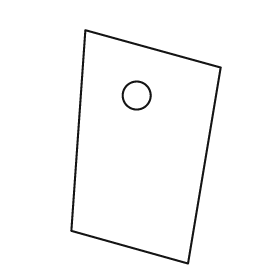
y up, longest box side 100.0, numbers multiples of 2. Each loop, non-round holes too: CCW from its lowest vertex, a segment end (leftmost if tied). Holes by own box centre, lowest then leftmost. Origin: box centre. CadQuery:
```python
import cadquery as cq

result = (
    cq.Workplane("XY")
    .moveTo(18.0, -50.0)
    .lineTo(32.0, 34.0)
    .lineTo(-26.0, 50.0)
    .lineTo(-32.0, -36.0)
    .close()
    .moveTo(-4.0, 22.0)
    .circle(6.0)
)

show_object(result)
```